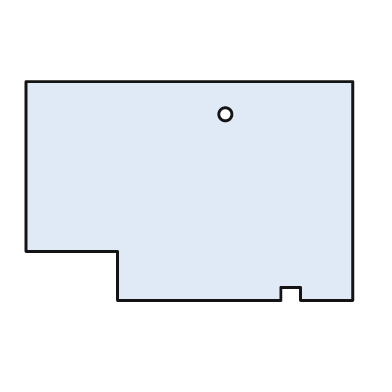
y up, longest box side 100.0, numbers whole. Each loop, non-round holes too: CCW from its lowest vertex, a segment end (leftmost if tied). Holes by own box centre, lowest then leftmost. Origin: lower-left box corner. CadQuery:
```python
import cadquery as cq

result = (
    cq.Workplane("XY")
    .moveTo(28.0, 0.0)
    .lineTo(78.0, 0.0)
    .lineTo(78.0, 4.0)
    .lineTo(84.0, 4.0)
    .lineTo(84.0, 0.0)
    .lineTo(100.0, 0.0)
    .lineTo(100.0, 67.0)
    .lineTo(0.0, 67.0)
    .lineTo(0.0, 15.0)
    .lineTo(28.0, 15.0)
    .close()
    .moveTo(61.0, 57.0)
    .circle(2.0)
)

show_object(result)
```